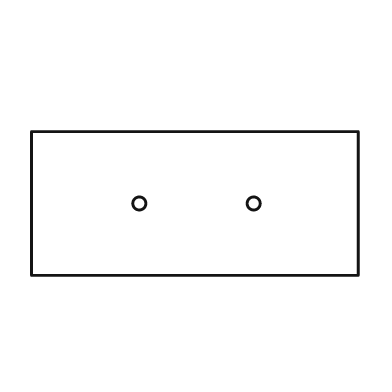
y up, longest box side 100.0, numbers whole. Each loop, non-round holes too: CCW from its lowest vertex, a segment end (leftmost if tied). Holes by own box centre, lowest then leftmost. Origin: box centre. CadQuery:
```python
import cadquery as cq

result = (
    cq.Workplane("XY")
    .moveTo(-50.0, -22.0)
    .lineTo(50.0, -22.0)
    .lineTo(50.0, 22.0)
    .lineTo(-50.0, 22.0)
    .close()
    .moveTo(-17.0, 0.0)
    .circle(2.0)
    .moveTo(18.0, 0.0)
    .circle(2.0)
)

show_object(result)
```